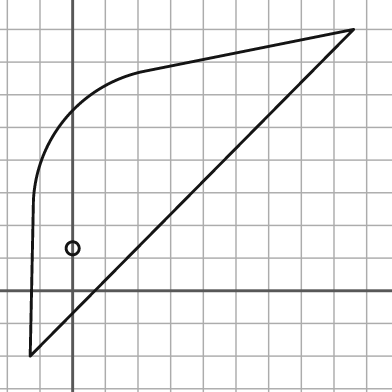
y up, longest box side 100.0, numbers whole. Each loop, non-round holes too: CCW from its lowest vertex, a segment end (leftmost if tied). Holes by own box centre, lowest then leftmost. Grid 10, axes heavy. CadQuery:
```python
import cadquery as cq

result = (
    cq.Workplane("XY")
    .moveTo(-13.0, -20.0)
    .lineTo(86.0, 80.0)
    .lineTo(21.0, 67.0)
    .threePointArc((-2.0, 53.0), (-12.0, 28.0))
    .close()
    .moveTo(0.0, 13.0)
    .circle(2.0)
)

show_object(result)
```